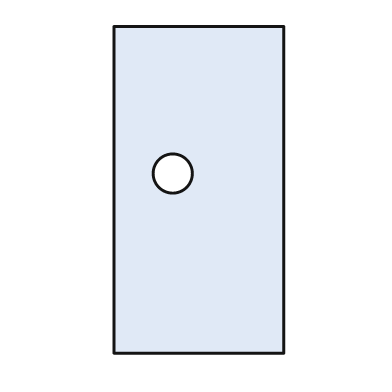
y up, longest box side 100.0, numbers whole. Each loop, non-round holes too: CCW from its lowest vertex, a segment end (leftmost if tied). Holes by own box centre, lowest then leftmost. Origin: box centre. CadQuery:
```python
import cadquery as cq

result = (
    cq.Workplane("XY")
    .moveTo(-26.0, -50.0)
    .lineTo(26.0, -50.0)
    .lineTo(26.0, 50.0)
    .lineTo(-26.0, 50.0)
    .close()
    .moveTo(-8.0, 5.0)
    .circle(6.0)
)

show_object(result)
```